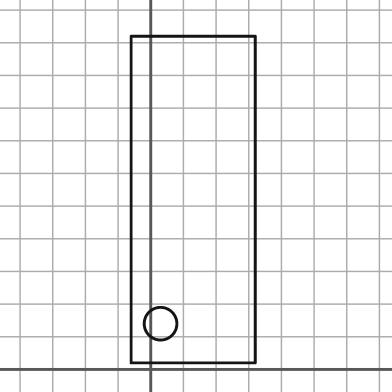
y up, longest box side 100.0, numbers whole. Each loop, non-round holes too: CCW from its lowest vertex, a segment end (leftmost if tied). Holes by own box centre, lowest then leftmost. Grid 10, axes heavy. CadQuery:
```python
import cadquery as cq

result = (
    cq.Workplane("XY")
    .moveTo(-6.0, 2.0)
    .lineTo(32.0, 2.0)
    .lineTo(32.0, 102.0)
    .lineTo(-6.0, 102.0)
    .close()
    .moveTo(3.0, 14.0)
    .circle(5.0)
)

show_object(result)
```